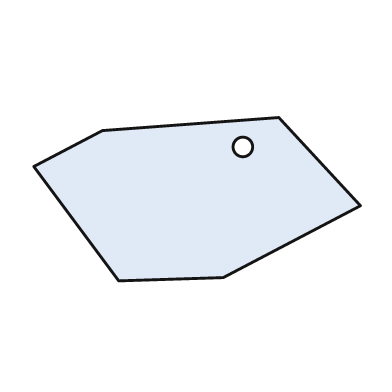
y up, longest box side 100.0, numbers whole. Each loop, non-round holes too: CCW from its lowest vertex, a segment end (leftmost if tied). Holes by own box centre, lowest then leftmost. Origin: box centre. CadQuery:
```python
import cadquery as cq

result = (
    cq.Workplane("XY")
    .moveTo(-24.0, -25.0)
    .lineTo(8.0, -24.0)
    .lineTo(50.0, -2.0)
    .lineTo(25.0, 25.0)
    .lineTo(-29.0, 21.0)
    .lineTo(-50.0, 10.0)
    .close()
    .moveTo(14.0, 16.0)
    .circle(3.0)
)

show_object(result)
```